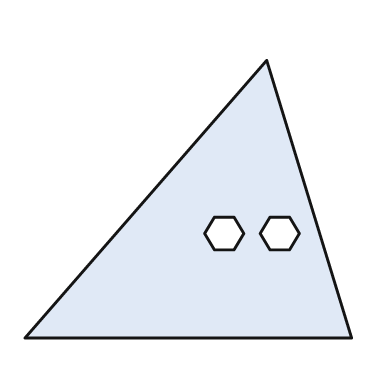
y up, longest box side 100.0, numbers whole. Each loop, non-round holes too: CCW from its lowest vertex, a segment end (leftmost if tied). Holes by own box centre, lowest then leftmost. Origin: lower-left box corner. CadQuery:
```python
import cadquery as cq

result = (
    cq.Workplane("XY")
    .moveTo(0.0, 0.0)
    .lineTo(100.0, 0.0)
    .lineTo(74.0, 85.0)
    .close()
    .moveTo(58.0, 27.0)
    .lineTo(64.0, 27.0)
    .lineTo(67.0, 32.0)
    .lineTo(64.0, 37.0)
    .lineTo(58.0, 37.0)
    .lineTo(55.0, 32.0)
    .close()
    .moveTo(75.0, 27.0)
    .lineTo(81.0, 27.0)
    .lineTo(84.0, 32.0)
    .lineTo(81.0, 37.0)
    .lineTo(75.0, 37.0)
    .lineTo(72.0, 32.0)
    .close()
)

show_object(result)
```